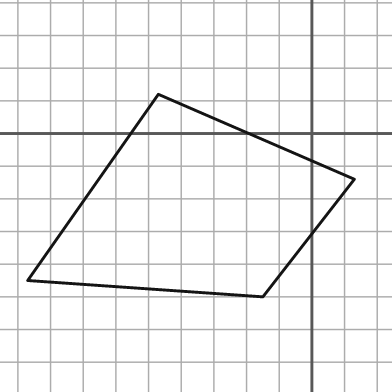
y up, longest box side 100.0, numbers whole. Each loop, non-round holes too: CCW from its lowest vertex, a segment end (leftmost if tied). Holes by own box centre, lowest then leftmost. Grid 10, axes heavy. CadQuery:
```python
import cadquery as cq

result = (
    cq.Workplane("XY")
    .moveTo(-15.0, -50.0)
    .lineTo(13.0, -14.0)
    .lineTo(-47.0, 12.0)
    .lineTo(-87.0, -45.0)
    .close()
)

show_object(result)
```